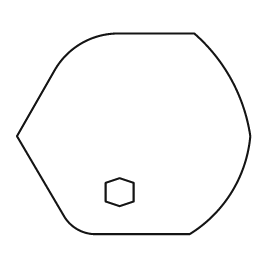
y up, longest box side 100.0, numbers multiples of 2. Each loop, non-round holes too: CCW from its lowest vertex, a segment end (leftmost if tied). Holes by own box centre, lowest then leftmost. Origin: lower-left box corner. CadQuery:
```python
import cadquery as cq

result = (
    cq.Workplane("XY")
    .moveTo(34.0, 0.0)
    .lineTo(74.0, 0.0)
    .threePointArc((92.0, 18.0), (100.0, 42.0))
    .threePointArc((92.0, 66.0), (76.0, 86.0))
    .lineTo(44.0, 86.0)
    .threePointArc((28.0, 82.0), (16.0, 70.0))
    .lineTo(0.0, 42.0)
    .lineTo(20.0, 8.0)
    .threePointArc((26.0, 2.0), (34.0, 0.0))
    .close()
    .moveTo(44.0, 12.0)
    .lineTo(50.0, 14.0)
    .lineTo(50.0, 22.0)
    .lineTo(44.0, 24.0)
    .lineTo(38.0, 22.0)
    .lineTo(38.0, 14.0)
    .close()
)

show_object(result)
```